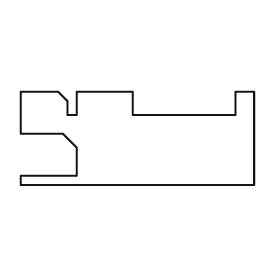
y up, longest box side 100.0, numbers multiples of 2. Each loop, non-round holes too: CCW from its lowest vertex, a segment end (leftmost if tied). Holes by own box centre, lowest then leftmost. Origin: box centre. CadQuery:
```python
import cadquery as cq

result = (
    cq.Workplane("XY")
    .moveTo(-50.0, -20.0)
    .lineTo(50.0, -20.0)
    .lineTo(50.0, 20.0)
    .lineTo(42.0, 20.0)
    .lineTo(42.0, 10.0)
    .lineTo(-2.0, 10.0)
    .lineTo(-2.0, 20.0)
    .lineTo(-26.0, 20.0)
    .lineTo(-26.0, 10.0)
    .lineTo(-30.0, 10.0)
    .lineTo(-30.0, 16.0)
    .lineTo(-34.0, 20.0)
    .lineTo(-50.0, 20.0)
    .lineTo(-50.0, 2.0)
    .lineTo(-32.0, 2.0)
    .lineTo(-26.0, -4.0)
    .lineTo(-26.0, -16.0)
    .lineTo(-50.0, -16.0)
    .close()
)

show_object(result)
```